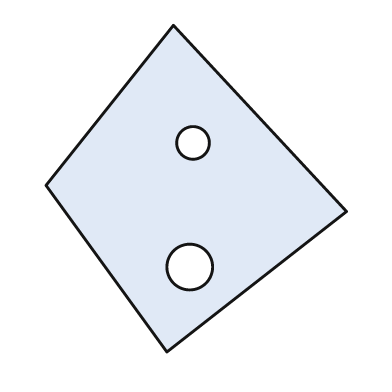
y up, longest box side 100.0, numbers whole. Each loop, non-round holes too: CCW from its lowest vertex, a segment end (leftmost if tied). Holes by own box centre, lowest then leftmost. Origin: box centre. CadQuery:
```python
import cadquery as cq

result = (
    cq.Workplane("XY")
    .moveTo(-9.0, -50.0)
    .lineTo(46.0, -7.0)
    .lineTo(-7.0, 50.0)
    .lineTo(-46.0, 1.0)
    .close()
    .moveTo(-2.0, -24.0)
    .circle(7.0)
    .moveTo(-1.0, 14.0)
    .circle(5.0)
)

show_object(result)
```